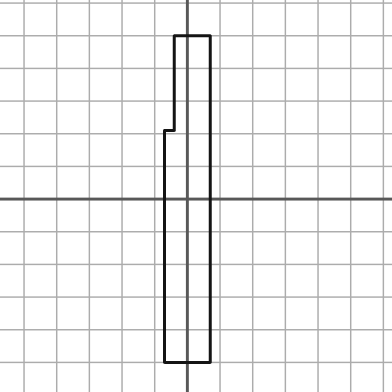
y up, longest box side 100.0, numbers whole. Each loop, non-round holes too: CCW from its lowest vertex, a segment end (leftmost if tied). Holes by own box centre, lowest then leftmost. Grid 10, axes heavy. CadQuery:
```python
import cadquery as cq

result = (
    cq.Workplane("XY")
    .moveTo(-7.0, -50.0)
    .lineTo(7.0, -50.0)
    .lineTo(7.0, 50.0)
    .lineTo(-4.0, 50.0)
    .lineTo(-4.0, 21.0)
    .lineTo(-7.0, 21.0)
    .close()
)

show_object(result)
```